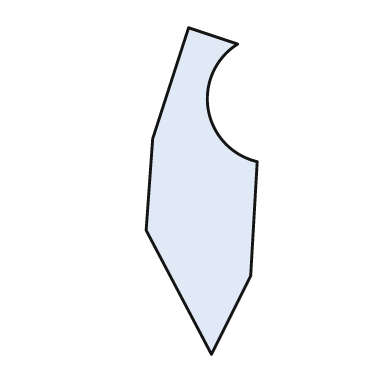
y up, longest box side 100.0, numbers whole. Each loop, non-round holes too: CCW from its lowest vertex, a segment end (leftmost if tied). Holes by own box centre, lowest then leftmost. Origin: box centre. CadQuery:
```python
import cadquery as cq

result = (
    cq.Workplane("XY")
    .moveTo(3.0, -50.0)
    .lineTo(15.0, -26.0)
    .lineTo(17.0, 9.0)
    .threePointArc((2.0, 25.0), (11.0, 45.0))
    .lineTo(-4.0, 50.0)
    .lineTo(-15.0, 16.0)
    .lineTo(-17.0, -12.0)
    .close()
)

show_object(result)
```